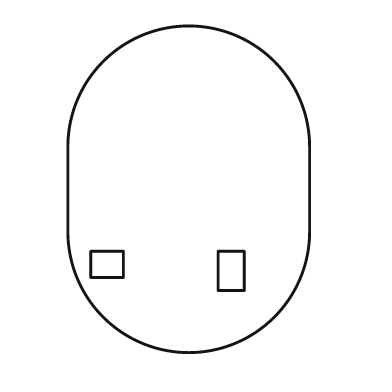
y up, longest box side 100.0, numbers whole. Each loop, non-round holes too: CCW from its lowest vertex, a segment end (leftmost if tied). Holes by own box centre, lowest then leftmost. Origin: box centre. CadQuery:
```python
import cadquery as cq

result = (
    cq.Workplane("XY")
    .moveTo(-37.0, -13.0)
    .threePointArc((0.0, -50.0), (37.0, -13.0))
    .lineTo(37.0, 13.0)
    .threePointArc((0.0, 50.0), (-37.0, 13.0))
    .close()
    .moveTo(9.0, -31.0)
    .lineTo(17.0, -31.0)
    .lineTo(17.0, -19.0)
    .lineTo(9.0, -19.0)
    .close()
    .moveTo(-30.0, -27.0)
    .lineTo(-20.0, -27.0)
    .lineTo(-20.0, -19.0)
    .lineTo(-30.0, -19.0)
    .close()
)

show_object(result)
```